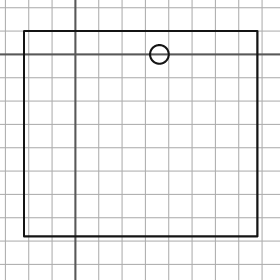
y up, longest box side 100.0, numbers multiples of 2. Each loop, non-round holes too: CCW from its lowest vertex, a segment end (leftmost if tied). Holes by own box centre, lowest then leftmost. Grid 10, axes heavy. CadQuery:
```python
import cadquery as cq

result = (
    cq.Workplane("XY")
    .moveTo(-22.0, -78.0)
    .lineTo(78.0, -78.0)
    .lineTo(78.0, 10.0)
    .lineTo(-22.0, 10.0)
    .close()
    .moveTo(36.0, 0.0)
    .circle(4.0)
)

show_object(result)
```